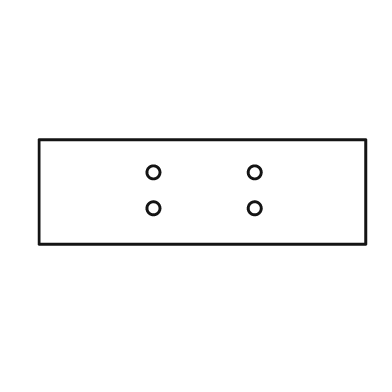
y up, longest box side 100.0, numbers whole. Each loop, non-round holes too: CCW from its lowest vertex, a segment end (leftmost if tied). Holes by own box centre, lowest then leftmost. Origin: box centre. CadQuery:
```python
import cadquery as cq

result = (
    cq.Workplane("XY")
    .moveTo(-50.0, -16.0)
    .lineTo(50.0, -16.0)
    .lineTo(50.0, 16.0)
    .lineTo(-50.0, 16.0)
    .close()
    .moveTo(-15.0, -5.0)
    .circle(2.0)
    .moveTo(16.0, -5.0)
    .circle(2.0)
    .moveTo(-15.0, 6.0)
    .circle(2.0)
    .moveTo(16.0, 6.0)
    .circle(2.0)
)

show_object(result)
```